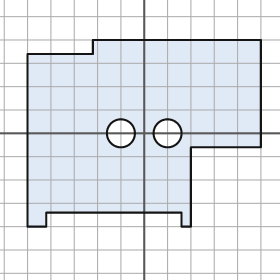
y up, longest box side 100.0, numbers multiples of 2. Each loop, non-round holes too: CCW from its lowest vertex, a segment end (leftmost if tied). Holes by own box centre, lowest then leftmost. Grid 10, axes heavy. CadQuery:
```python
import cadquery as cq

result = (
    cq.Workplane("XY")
    .moveTo(-50.0, -40.0)
    .lineTo(-42.0, -40.0)
    .lineTo(-42.0, -34.0)
    .lineTo(16.0, -34.0)
    .lineTo(16.0, -40.0)
    .lineTo(20.0, -40.0)
    .lineTo(20.0, -6.0)
    .lineTo(50.0, -6.0)
    .lineTo(50.0, 40.0)
    .lineTo(-22.0, 40.0)
    .lineTo(-22.0, 34.0)
    .lineTo(-50.0, 34.0)
    .close()
    .moveTo(-10.0, 0.0)
    .circle(6.0)
    .moveTo(10.0, 0.0)
    .circle(6.0)
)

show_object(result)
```